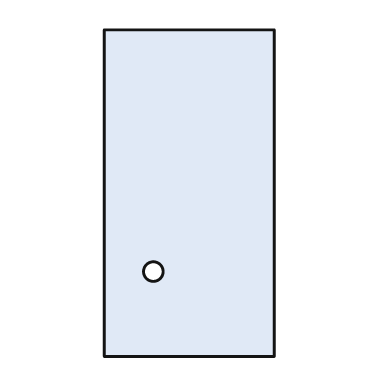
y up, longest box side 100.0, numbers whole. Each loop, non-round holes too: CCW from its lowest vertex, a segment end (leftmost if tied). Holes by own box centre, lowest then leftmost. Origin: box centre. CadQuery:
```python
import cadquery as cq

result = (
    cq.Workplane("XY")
    .moveTo(-26.0, -50.0)
    .lineTo(26.0, -50.0)
    .lineTo(26.0, 50.0)
    .lineTo(-26.0, 50.0)
    .close()
    .moveTo(-11.0, -24.0)
    .circle(3.0)
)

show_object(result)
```